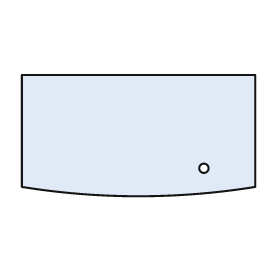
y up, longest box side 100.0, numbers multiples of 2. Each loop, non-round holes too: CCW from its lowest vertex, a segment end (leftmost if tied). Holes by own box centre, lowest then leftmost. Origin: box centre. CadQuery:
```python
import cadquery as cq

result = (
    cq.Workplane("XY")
    .moveTo(-50.0, -22.0)
    .threePointArc((0.0, -26.0), (50.0, -22.0))
    .lineTo(50.0, 26.0)
    .lineTo(-50.0, 26.0)
    .close()
    .moveTo(28.0, -14.0)
    .circle(2.0)
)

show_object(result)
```